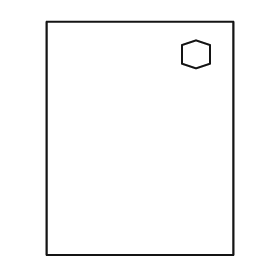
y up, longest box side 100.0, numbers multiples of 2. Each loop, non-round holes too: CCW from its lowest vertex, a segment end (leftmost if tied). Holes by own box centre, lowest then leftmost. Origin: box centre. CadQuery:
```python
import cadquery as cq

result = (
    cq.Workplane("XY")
    .moveTo(-40.0, -50.0)
    .lineTo(40.0, -50.0)
    .lineTo(40.0, 50.0)
    .lineTo(-40.0, 50.0)
    .close()
    .moveTo(24.0, 30.0)
    .lineTo(30.0, 32.0)
    .lineTo(30.0, 40.0)
    .lineTo(24.0, 42.0)
    .lineTo(18.0, 40.0)
    .lineTo(18.0, 32.0)
    .close()
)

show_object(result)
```